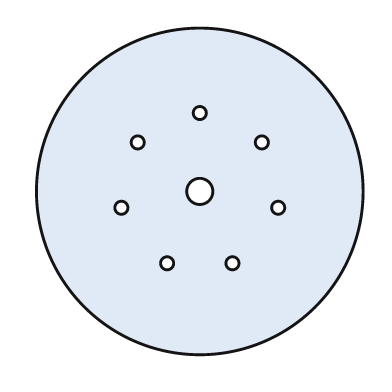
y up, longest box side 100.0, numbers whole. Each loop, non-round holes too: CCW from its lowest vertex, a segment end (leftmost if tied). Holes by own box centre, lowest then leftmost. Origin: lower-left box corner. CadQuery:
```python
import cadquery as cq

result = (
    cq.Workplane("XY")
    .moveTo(50.0, 50.0)
    .circle(50.0)
    .moveTo(40.0, 28.0)
    .circle(2.0)
    .moveTo(60.0, 28.0)
    .circle(2.0)
    .moveTo(26.0, 45.0)
    .circle(2.0)
    .moveTo(74.0, 45.0)
    .circle(2.0)
    .moveTo(50.0, 50.0)
    .circle(4.0)
    .moveTo(31.0, 65.0)
    .circle(2.0)
    .moveTo(69.0, 65.0)
    .circle(2.0)
    .moveTo(50.0, 74.0)
    .circle(2.0)
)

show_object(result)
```